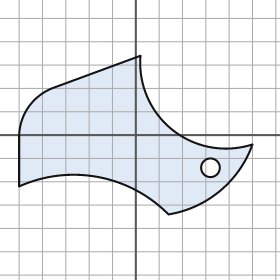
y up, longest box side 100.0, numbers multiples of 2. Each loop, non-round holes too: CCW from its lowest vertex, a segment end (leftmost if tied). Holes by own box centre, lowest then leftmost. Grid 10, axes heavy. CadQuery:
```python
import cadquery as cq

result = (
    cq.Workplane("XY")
    .moveTo(14.0, -34.0)
    .threePointArc((36.0, -24.0), (50.0, -4.0))
    .threePointArc((16.0, 2.0), (2.0, 34.0))
    .lineTo(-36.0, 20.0)
    .threePointArc((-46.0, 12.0), (-50.0, 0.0))
    .lineTo(-50.0, -22.0)
    .threePointArc((-16.0, -18.0), (14.0, -34.0))
    .close()
    .moveTo(32.0, -14.0)
    .circle(4.0)
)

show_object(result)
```